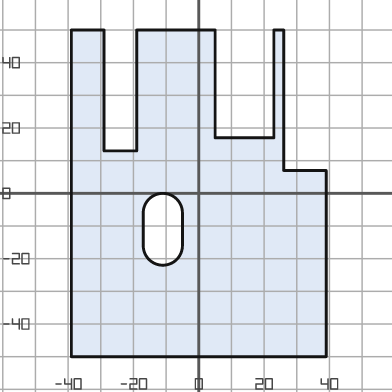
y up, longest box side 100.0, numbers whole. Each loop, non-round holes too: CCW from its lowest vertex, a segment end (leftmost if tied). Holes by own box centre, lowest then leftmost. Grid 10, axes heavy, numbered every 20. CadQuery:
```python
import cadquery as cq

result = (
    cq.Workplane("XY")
    .moveTo(-39.0, -50.0)
    .lineTo(39.0, -50.0)
    .lineTo(39.0, 7.0)
    .lineTo(26.0, 7.0)
    .lineTo(26.0, 50.0)
    .lineTo(23.0, 50.0)
    .lineTo(23.0, 17.0)
    .lineTo(5.0, 17.0)
    .lineTo(5.0, 50.0)
    .lineTo(-19.0, 50.0)
    .lineTo(-19.0, 13.0)
    .lineTo(-29.0, 13.0)
    .lineTo(-29.0, 50.0)
    .lineTo(-39.0, 50.0)
    .close()
    .moveTo(-17.0, -16.0)
    .threePointArc((-11.0, -22.0), (-5.0, -16.0))
    .lineTo(-5.0, -6.0)
    .threePointArc((-11.0, 0.0), (-17.0, -6.0))
    .close()
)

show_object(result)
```